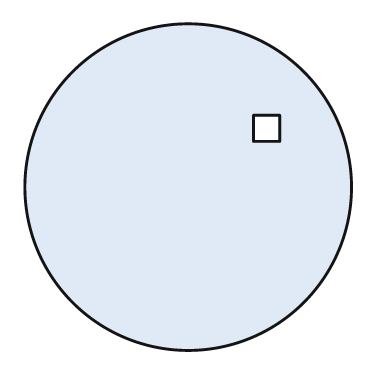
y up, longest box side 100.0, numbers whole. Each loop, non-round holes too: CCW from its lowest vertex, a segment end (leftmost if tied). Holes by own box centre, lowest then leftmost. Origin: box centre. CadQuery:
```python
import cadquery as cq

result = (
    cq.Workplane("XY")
    .moveTo(0.0, 0.0)
    .circle(50.0)
    .moveTo(20.0, 14.0)
    .lineTo(28.0, 14.0)
    .lineTo(28.0, 22.0)
    .lineTo(20.0, 22.0)
    .close()
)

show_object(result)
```